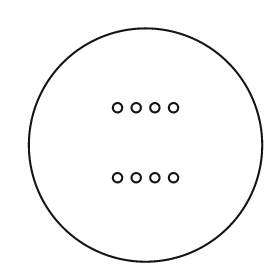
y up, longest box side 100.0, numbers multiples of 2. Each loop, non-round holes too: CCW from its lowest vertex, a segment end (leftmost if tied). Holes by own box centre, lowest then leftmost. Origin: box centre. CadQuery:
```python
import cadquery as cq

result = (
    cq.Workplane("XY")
    .moveTo(0.0, 0.0)
    .circle(50.0)
    .moveTo(-12.0, -14.0)
    .circle(2.0)
    .moveTo(-4.0, -14.0)
    .circle(2.0)
    .moveTo(4.0, -14.0)
    .circle(2.0)
    .moveTo(12.0, -14.0)
    .circle(2.0)
    .moveTo(-12.0, 16.0)
    .circle(2.0)
    .moveTo(-4.0, 16.0)
    .circle(2.0)
    .moveTo(4.0, 16.0)
    .circle(2.0)
    .moveTo(12.0, 16.0)
    .circle(2.0)
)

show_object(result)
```